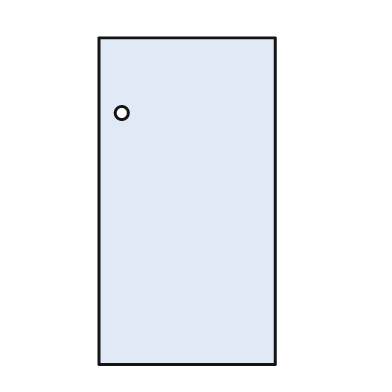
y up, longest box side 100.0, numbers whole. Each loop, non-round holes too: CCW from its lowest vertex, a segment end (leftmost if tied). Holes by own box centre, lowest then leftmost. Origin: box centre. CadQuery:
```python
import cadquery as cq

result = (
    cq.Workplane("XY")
    .moveTo(-27.0, -50.0)
    .lineTo(27.0, -50.0)
    .lineTo(27.0, 50.0)
    .lineTo(-27.0, 50.0)
    .close()
    .moveTo(-20.0, 27.0)
    .circle(2.0)
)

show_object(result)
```